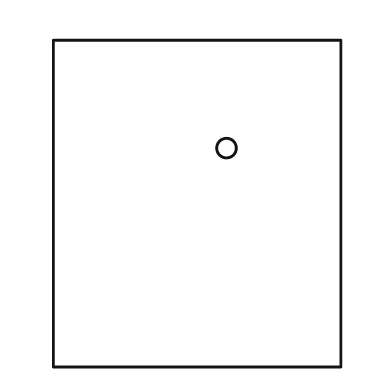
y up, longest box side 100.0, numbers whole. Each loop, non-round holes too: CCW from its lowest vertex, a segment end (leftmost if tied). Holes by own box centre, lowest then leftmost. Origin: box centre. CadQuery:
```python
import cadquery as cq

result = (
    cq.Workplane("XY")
    .moveTo(-44.0, -50.0)
    .lineTo(44.0, -50.0)
    .lineTo(44.0, 50.0)
    .lineTo(-44.0, 50.0)
    .close()
    .moveTo(9.0, 17.0)
    .circle(3.0)
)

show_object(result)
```